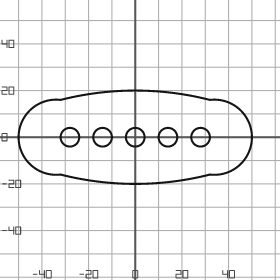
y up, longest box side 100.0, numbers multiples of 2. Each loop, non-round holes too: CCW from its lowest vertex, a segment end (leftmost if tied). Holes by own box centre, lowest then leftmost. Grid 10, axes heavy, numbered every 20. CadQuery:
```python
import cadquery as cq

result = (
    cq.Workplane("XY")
    .moveTo(-32.0, -16.0)
    .threePointArc((0.0, -20.0), (32.0, -16.0))
    .threePointArc((50.0, 0.0), (32.0, 16.0))
    .threePointArc((0.0, 20.0), (-32.0, 16.0))
    .threePointArc((-50.0, 0.0), (-32.0, -16.0))
    .close()
    .moveTo(-28.0, 0.0)
    .circle(4.0)
    .moveTo(-14.0, 0.0)
    .circle(4.0)
    .moveTo(0.0, 0.0)
    .circle(4.0)
    .moveTo(14.0, 0.0)
    .circle(4.0)
    .moveTo(28.0, 0.0)
    .circle(4.0)
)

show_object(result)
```